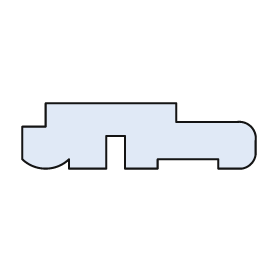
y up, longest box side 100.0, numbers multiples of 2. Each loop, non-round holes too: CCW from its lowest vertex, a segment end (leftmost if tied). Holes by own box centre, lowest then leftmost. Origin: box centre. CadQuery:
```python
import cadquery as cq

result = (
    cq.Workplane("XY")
    .moveTo(-30.0, -14.0)
    .lineTo(-14.0, -14.0)
    .lineTo(-14.0, 0.0)
    .lineTo(-6.0, 0.0)
    .lineTo(-6.0, -14.0)
    .lineTo(8.0, -14.0)
    .lineTo(8.0, -10.0)
    .lineTo(34.0, -10.0)
    .lineTo(34.0, -14.0)
    .lineTo(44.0, -14.0)
    .threePointArc((48.0, -12.0), (50.0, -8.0))
    .lineTo(50.0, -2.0)
    .threePointArc((48.0, 4.0), (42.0, 6.0))
    .lineTo(16.0, 6.0)
    .lineTo(16.0, 14.0)
    .lineTo(-40.0, 14.0)
    .lineTo(-40.0, 4.0)
    .lineTo(-50.0, 4.0)
    .lineTo(-50.0, -10.0)
    .threePointArc((-40.0, -14.0), (-30.0, -10.0))
    .close()
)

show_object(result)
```